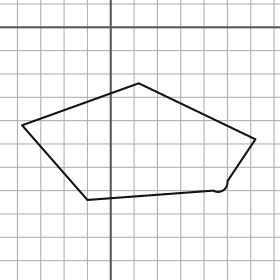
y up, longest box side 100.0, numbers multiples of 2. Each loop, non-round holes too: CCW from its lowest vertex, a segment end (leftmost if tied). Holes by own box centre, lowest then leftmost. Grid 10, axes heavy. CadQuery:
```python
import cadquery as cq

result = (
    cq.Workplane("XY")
    .moveTo(-10.0, -74.0)
    .lineTo(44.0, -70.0)
    .threePointArc((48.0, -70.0), (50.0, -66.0))
    .lineTo(62.0, -48.0)
    .lineTo(12.0, -24.0)
    .lineTo(-38.0, -42.0)
    .close()
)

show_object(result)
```